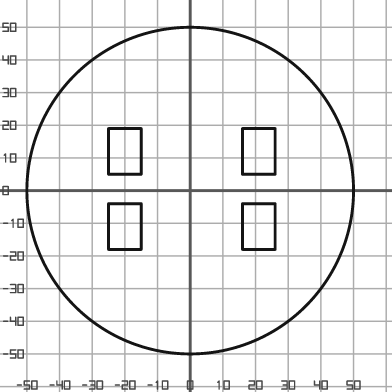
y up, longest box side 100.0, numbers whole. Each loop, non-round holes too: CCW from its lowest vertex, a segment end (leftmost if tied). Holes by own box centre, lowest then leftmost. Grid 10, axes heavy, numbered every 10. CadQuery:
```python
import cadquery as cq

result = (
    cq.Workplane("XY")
    .moveTo(0.0, 0.0)
    .circle(50.0)
    .moveTo(-25.0, -18.0)
    .lineTo(-15.0, -18.0)
    .lineTo(-15.0, -4.0)
    .lineTo(-25.0, -4.0)
    .close()
    .moveTo(16.0, -18.0)
    .lineTo(26.0, -18.0)
    .lineTo(26.0, -4.0)
    .lineTo(16.0, -4.0)
    .close()
    .moveTo(-25.0, 5.0)
    .lineTo(-15.0, 5.0)
    .lineTo(-15.0, 19.0)
    .lineTo(-25.0, 19.0)
    .close()
    .moveTo(16.0, 5.0)
    .lineTo(26.0, 5.0)
    .lineTo(26.0, 19.0)
    .lineTo(16.0, 19.0)
    .close()
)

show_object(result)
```